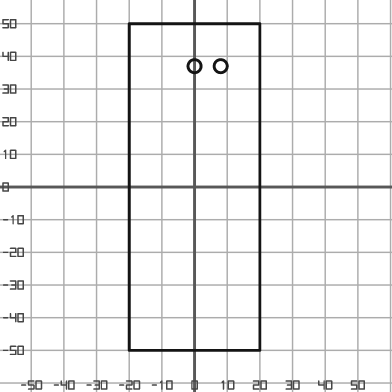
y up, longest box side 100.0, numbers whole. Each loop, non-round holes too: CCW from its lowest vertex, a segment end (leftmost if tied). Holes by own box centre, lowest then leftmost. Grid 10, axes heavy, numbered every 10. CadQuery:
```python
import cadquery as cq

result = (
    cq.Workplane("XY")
    .moveTo(-20.0, -50.0)
    .lineTo(20.0, -50.0)
    .lineTo(20.0, 50.0)
    .lineTo(-20.0, 50.0)
    .close()
    .moveTo(0.0, 37.0)
    .circle(2.0)
    .moveTo(8.0, 37.0)
    .circle(2.0)
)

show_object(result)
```